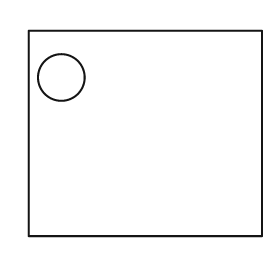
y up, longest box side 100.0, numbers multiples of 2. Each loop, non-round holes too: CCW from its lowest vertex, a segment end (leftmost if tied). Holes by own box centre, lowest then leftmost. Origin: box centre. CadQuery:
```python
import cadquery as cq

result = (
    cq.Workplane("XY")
    .moveTo(-50.0, -44.0)
    .lineTo(50.0, -44.0)
    .lineTo(50.0, 44.0)
    .lineTo(-50.0, 44.0)
    .close()
    .moveTo(-36.0, 24.0)
    .circle(10.0)
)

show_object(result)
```